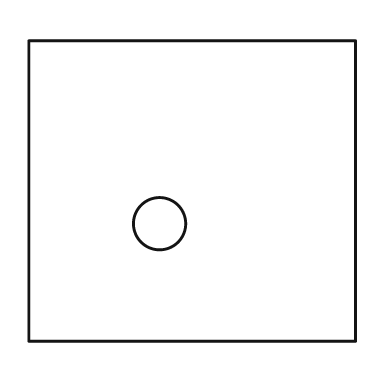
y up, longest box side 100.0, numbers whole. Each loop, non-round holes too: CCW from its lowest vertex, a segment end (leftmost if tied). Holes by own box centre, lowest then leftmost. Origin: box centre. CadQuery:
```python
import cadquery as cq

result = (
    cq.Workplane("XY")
    .moveTo(-50.0, -46.0)
    .lineTo(50.0, -46.0)
    .lineTo(50.0, 46.0)
    .lineTo(-50.0, 46.0)
    .close()
    .moveTo(-10.0, -10.0)
    .circle(8.0)
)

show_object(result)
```